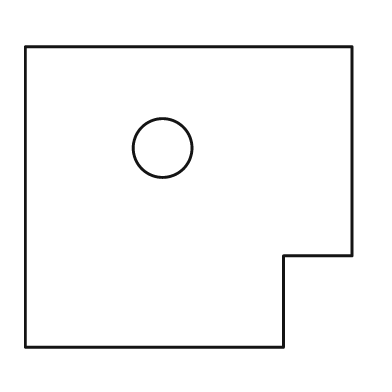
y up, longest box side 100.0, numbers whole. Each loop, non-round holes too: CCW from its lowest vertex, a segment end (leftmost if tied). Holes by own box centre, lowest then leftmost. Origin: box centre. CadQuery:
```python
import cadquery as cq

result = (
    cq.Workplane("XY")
    .moveTo(-50.0, -46.0)
    .lineTo(29.0, -46.0)
    .lineTo(29.0, -18.0)
    .lineTo(50.0, -18.0)
    .lineTo(50.0, 46.0)
    .lineTo(-50.0, 46.0)
    .close()
    .moveTo(-8.0, 15.0)
    .circle(9.0)
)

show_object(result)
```